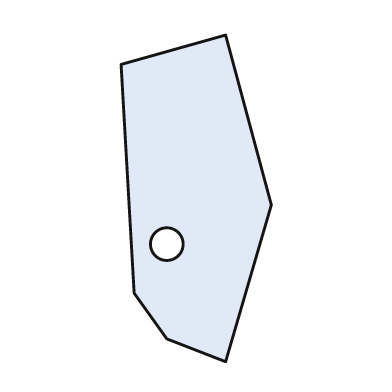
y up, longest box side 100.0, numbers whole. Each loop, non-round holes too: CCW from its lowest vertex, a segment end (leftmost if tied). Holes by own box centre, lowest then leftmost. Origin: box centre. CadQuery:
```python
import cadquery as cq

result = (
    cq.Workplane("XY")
    .moveTo(9.0, -50.0)
    .lineTo(23.0, -2.0)
    .lineTo(9.0, 50.0)
    .lineTo(-23.0, 41.0)
    .lineTo(-19.0, -29.0)
    .lineTo(-9.0, -43.0)
    .close()
    .moveTo(-9.0, -14.0)
    .circle(5.0)
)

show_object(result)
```